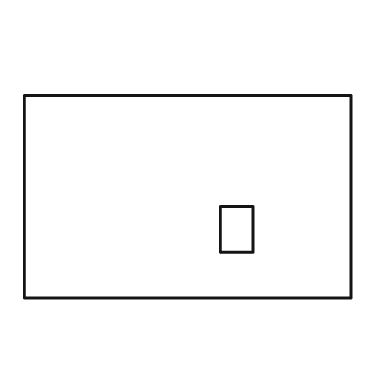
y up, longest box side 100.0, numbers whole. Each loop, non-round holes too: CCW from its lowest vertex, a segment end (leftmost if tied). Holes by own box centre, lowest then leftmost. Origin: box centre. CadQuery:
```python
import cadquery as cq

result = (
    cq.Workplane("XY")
    .moveTo(-50.0, -31.0)
    .lineTo(50.0, -31.0)
    .lineTo(50.0, 31.0)
    .lineTo(-50.0, 31.0)
    .close()
    .moveTo(10.0, -17.0)
    .lineTo(20.0, -17.0)
    .lineTo(20.0, -3.0)
    .lineTo(10.0, -3.0)
    .close()
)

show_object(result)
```